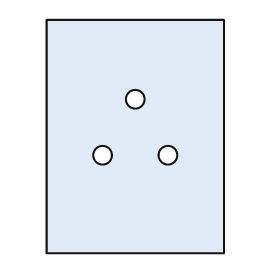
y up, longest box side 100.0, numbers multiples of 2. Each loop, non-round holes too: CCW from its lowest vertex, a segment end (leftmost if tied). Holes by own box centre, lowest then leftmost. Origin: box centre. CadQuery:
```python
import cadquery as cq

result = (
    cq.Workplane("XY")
    .moveTo(-38.0, -50.0)
    .lineTo(38.0, -50.0)
    .lineTo(38.0, 50.0)
    .lineTo(-38.0, 50.0)
    .close()
    .moveTo(-14.0, -8.0)
    .circle(4.0)
    .moveTo(14.0, -8.0)
    .circle(4.0)
    .moveTo(0.0, 16.0)
    .circle(4.0)
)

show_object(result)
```